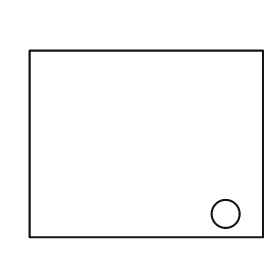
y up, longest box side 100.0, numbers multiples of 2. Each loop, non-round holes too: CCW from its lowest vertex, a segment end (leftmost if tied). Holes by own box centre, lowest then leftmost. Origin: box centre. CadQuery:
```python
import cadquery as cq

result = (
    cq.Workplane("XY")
    .moveTo(-50.0, -40.0)
    .lineTo(50.0, -40.0)
    .lineTo(50.0, 40.0)
    .lineTo(-50.0, 40.0)
    .close()
    .moveTo(34.0, -30.0)
    .circle(6.0)
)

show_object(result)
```